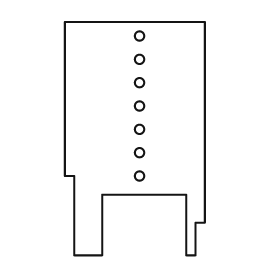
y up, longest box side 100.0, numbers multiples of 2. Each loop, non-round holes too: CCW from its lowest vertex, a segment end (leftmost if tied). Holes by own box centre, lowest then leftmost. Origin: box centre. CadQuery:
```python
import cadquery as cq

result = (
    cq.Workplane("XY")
    .moveTo(-26.0, -50.0)
    .lineTo(-14.0, -50.0)
    .lineTo(-14.0, -24.0)
    .lineTo(22.0, -24.0)
    .lineTo(22.0, -50.0)
    .lineTo(26.0, -50.0)
    .lineTo(26.0, -36.0)
    .lineTo(30.0, -36.0)
    .lineTo(30.0, 50.0)
    .lineTo(-30.0, 50.0)
    .lineTo(-30.0, -16.0)
    .lineTo(-26.0, -16.0)
    .close()
    .moveTo(2.0, -16.0)
    .circle(2.0)
    .moveTo(2.0, -6.0)
    .circle(2.0)
    .moveTo(2.0, 4.0)
    .circle(2.0)
    .moveTo(2.0, 14.0)
    .circle(2.0)
    .moveTo(2.0, 24.0)
    .circle(2.0)
    .moveTo(2.0, 34.0)
    .circle(2.0)
    .moveTo(2.0, 44.0)
    .circle(2.0)
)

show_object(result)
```